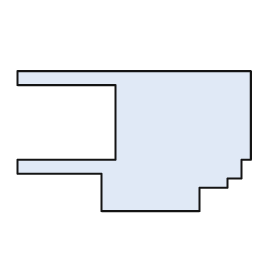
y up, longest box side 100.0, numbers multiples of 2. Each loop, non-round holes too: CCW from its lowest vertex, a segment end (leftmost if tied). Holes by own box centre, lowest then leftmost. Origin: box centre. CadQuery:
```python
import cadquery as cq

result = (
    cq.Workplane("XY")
    .moveTo(-14.0, -30.0)
    .lineTo(28.0, -30.0)
    .lineTo(28.0, -20.0)
    .lineTo(40.0, -20.0)
    .lineTo(40.0, -16.0)
    .lineTo(46.0, -16.0)
    .lineTo(46.0, -8.0)
    .lineTo(50.0, -8.0)
    .lineTo(50.0, 30.0)
    .lineTo(-50.0, 30.0)
    .lineTo(-50.0, 24.0)
    .lineTo(-8.0, 24.0)
    .lineTo(-8.0, -8.0)
    .lineTo(-50.0, -8.0)
    .lineTo(-50.0, -14.0)
    .lineTo(-14.0, -14.0)
    .close()
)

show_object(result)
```